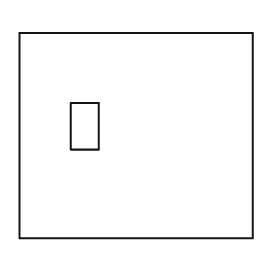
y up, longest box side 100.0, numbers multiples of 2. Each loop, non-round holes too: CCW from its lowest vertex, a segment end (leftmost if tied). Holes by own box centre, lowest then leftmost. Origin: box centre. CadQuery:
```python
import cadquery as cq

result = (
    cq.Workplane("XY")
    .moveTo(-50.0, -44.0)
    .lineTo(50.0, -44.0)
    .lineTo(50.0, 44.0)
    .lineTo(-50.0, 44.0)
    .close()
    .moveTo(-28.0, -6.0)
    .lineTo(-16.0, -6.0)
    .lineTo(-16.0, 14.0)
    .lineTo(-28.0, 14.0)
    .close()
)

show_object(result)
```